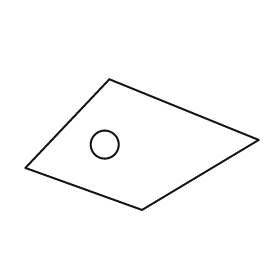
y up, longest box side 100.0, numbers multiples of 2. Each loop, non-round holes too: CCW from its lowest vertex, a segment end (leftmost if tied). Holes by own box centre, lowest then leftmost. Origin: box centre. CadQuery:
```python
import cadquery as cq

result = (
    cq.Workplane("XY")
    .moveTo(0.0, -28.0)
    .lineTo(50.0, 2.0)
    .lineTo(-14.0, 28.0)
    .lineTo(-50.0, -10.0)
    .close()
    .moveTo(-16.0, 0.0)
    .circle(6.0)
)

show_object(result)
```